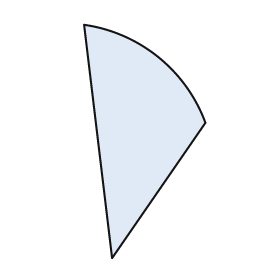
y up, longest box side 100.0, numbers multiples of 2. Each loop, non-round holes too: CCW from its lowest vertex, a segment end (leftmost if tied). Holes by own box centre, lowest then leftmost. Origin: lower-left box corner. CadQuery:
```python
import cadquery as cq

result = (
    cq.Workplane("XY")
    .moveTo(12.0, 0.0)
    .lineTo(52.0, 58.0)
    .threePointArc((32.0, 86.0), (0.0, 100.0))
    .close()
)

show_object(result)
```